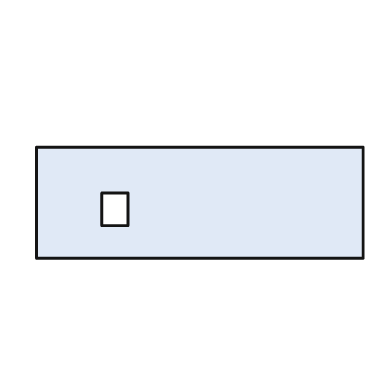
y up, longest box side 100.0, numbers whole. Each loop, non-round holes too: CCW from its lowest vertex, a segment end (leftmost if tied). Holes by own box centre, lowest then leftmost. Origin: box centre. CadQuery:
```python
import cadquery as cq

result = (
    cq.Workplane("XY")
    .moveTo(-50.0, -17.0)
    .lineTo(50.0, -17.0)
    .lineTo(50.0, 17.0)
    .lineTo(-50.0, 17.0)
    .close()
    .moveTo(-30.0, -7.0)
    .lineTo(-22.0, -7.0)
    .lineTo(-22.0, 3.0)
    .lineTo(-30.0, 3.0)
    .close()
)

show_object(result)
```